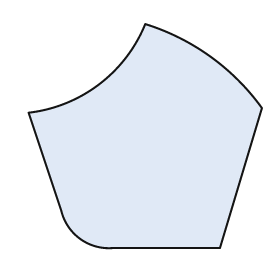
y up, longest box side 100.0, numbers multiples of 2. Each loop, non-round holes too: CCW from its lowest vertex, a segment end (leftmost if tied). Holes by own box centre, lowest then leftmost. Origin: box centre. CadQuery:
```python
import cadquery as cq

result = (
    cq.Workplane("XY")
    .moveTo(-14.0, -48.0)
    .lineTo(32.0, -48.0)
    .lineTo(50.0, 12.0)
    .threePointArc((28.0, 34.0), (0.0, 48.0))
    .threePointArc((-20.0, 22.0), (-50.0, 10.0))
    .lineTo(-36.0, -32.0)
    .threePointArc((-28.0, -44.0), (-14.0, -48.0))
    .close()
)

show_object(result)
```